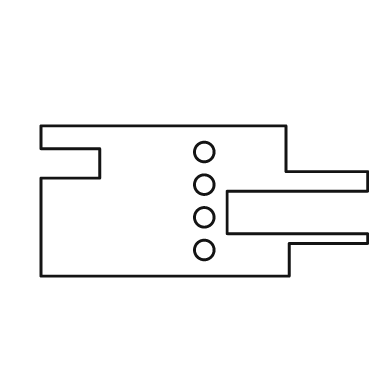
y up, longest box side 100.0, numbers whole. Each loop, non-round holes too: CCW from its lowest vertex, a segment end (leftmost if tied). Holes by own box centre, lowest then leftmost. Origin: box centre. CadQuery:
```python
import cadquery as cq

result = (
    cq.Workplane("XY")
    .moveTo(-50.0, -23.0)
    .lineTo(26.0, -23.0)
    .lineTo(26.0, -13.0)
    .lineTo(50.0, -13.0)
    .lineTo(50.0, -10.0)
    .lineTo(7.0, -10.0)
    .lineTo(7.0, 3.0)
    .lineTo(50.0, 3.0)
    .lineTo(50.0, 9.0)
    .lineTo(25.0, 9.0)
    .lineTo(25.0, 23.0)
    .lineTo(-50.0, 23.0)
    .lineTo(-50.0, 16.0)
    .lineTo(-32.0, 16.0)
    .lineTo(-32.0, 7.0)
    .lineTo(-50.0, 7.0)
    .close()
    .moveTo(0.0, -15.0)
    .circle(3.0)
    .moveTo(0.0, -5.0)
    .circle(3.0)
    .moveTo(0.0, 5.0)
    .circle(3.0)
    .moveTo(0.0, 15.0)
    .circle(3.0)
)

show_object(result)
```